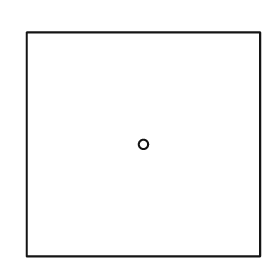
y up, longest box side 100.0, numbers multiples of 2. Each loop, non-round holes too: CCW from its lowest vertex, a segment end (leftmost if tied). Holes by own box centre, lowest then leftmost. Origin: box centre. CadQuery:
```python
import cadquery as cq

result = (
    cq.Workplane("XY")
    .moveTo(-50.0, -48.0)
    .lineTo(50.0, -48.0)
    .lineTo(50.0, 48.0)
    .lineTo(-50.0, 48.0)
    .close()
    .moveTo(0.0, 0.0)
    .circle(2.0)
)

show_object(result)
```